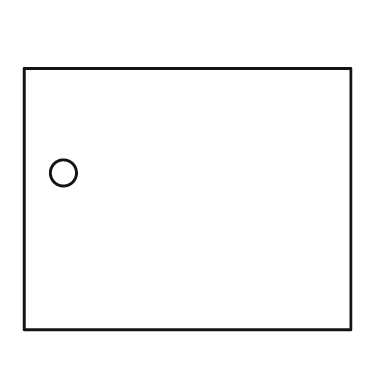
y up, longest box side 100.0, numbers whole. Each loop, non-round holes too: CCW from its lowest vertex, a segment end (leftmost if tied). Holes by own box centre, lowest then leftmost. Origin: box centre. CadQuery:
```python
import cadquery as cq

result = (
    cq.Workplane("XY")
    .moveTo(-50.0, -40.0)
    .lineTo(50.0, -40.0)
    .lineTo(50.0, 40.0)
    .lineTo(-50.0, 40.0)
    .close()
    .moveTo(-38.0, 8.0)
    .circle(4.0)
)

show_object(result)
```